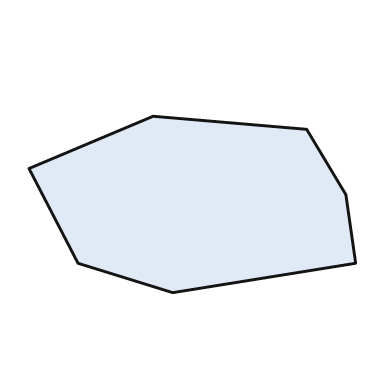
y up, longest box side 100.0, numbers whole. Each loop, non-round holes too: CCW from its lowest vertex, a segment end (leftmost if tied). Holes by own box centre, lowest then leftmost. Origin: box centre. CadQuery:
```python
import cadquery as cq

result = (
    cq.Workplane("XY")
    .moveTo(-6.0, -27.0)
    .lineTo(50.0, -18.0)
    .lineTo(47.0, 3.0)
    .lineTo(35.0, 23.0)
    .lineTo(-12.0, 27.0)
    .lineTo(-50.0, 11.0)
    .lineTo(-35.0, -18.0)
    .close()
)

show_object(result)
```